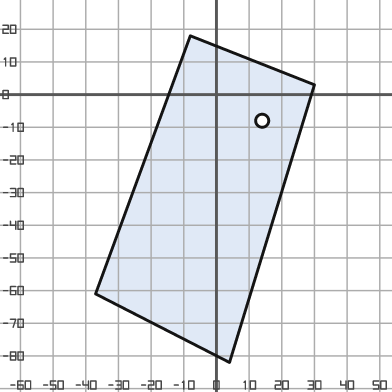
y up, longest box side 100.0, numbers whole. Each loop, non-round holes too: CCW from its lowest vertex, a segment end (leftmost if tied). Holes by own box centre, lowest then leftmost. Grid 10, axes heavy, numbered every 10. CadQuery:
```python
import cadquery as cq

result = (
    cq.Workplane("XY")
    .moveTo(4.0, -82.0)
    .lineTo(30.0, 3.0)
    .lineTo(-8.0, 18.0)
    .lineTo(-37.0, -61.0)
    .close()
    .moveTo(14.0, -8.0)
    .circle(2.0)
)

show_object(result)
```